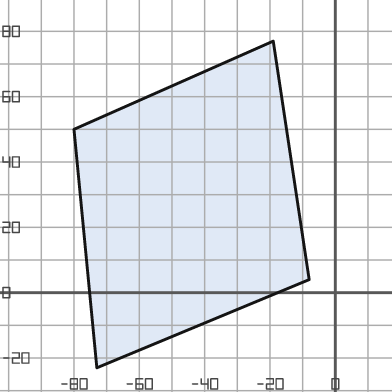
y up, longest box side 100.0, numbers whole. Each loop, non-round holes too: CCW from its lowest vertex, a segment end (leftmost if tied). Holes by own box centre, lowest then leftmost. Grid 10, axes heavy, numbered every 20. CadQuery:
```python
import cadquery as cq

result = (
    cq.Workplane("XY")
    .moveTo(-73.0, -23.0)
    .lineTo(-8.0, 4.0)
    .lineTo(-19.0, 77.0)
    .lineTo(-80.0, 50.0)
    .close()
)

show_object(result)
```